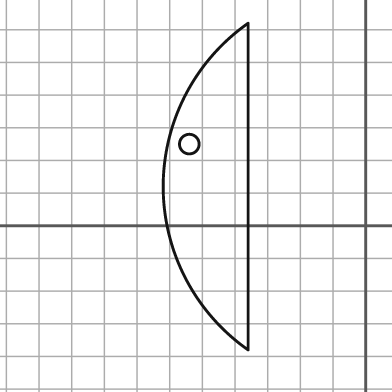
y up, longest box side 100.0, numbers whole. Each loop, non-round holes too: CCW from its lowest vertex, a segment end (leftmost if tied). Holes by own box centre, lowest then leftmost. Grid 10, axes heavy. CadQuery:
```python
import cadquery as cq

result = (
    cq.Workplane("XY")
    .moveTo(-36.0, -38.0)
    .lineTo(-36.0, 62.0)
    .threePointArc((-62.0, 12.0), (-36.0, -38.0))
    .close()
    .moveTo(-54.0, 25.0)
    .circle(3.0)
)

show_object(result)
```